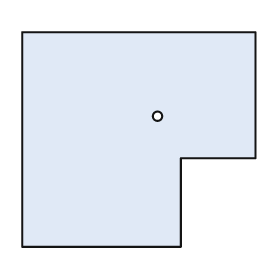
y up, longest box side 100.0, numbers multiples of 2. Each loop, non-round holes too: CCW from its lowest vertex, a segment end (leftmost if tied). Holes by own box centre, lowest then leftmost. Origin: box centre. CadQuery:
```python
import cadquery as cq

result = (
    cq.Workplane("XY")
    .moveTo(-50.0, -46.0)
    .lineTo(18.0, -46.0)
    .lineTo(18.0, -8.0)
    .lineTo(50.0, -8.0)
    .lineTo(50.0, 46.0)
    .lineTo(-50.0, 46.0)
    .close()
    .moveTo(8.0, 10.0)
    .circle(2.0)
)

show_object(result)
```